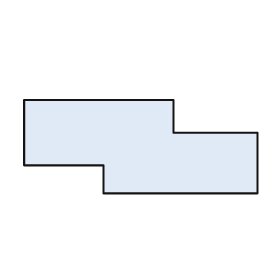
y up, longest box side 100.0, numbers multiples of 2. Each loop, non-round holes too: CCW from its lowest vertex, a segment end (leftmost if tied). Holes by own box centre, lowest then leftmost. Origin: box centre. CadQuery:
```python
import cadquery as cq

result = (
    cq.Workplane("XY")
    .moveTo(-16.0, -20.0)
    .lineTo(50.0, -20.0)
    .lineTo(50.0, 6.0)
    .lineTo(14.0, 6.0)
    .lineTo(14.0, 20.0)
    .lineTo(-50.0, 20.0)
    .lineTo(-50.0, -8.0)
    .lineTo(-16.0, -8.0)
    .close()
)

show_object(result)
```